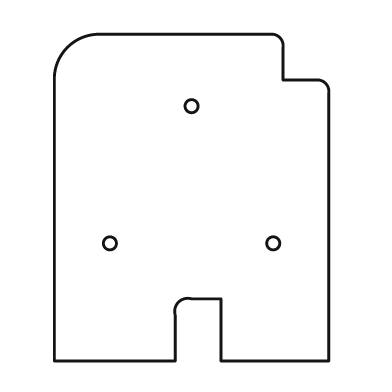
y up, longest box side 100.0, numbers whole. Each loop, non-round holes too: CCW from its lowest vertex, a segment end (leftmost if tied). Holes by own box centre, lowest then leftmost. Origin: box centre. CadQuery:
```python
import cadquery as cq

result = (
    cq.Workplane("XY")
    .moveTo(-42.0, -50.0)
    .lineTo(-5.0, -50.0)
    .lineTo(-5.0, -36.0)
    .threePointArc((-4.0, -32.0), (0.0, -31.0))
    .lineTo(9.0, -31.0)
    .lineTo(9.0, -50.0)
    .lineTo(42.0, -50.0)
    .lineTo(42.0, 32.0)
    .threePointArc((41.0, 35.0), (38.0, 36.0))
    .lineTo(28.0, 36.0)
    .lineTo(28.0, 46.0)
    .threePointArc((27.0, 49.0), (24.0, 50.0))
    .lineTo(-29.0, 50.0)
    .threePointArc((-38.0, 46.0), (-42.0, 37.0))
    .close()
    .moveTo(-25.0, -14.0)
    .circle(2.0)
    .moveTo(25.0, -14.0)
    .circle(2.0)
    .moveTo(0.0, 28.0)
    .circle(2.0)
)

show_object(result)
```